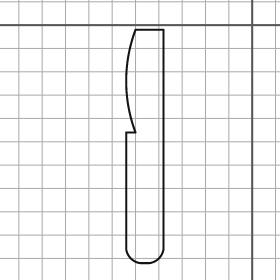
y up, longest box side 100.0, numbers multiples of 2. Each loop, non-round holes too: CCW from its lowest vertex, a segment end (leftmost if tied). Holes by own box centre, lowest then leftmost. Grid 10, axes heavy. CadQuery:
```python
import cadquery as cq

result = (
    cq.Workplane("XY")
    .moveTo(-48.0, -102.0)
    .lineTo(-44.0, -102.0)
    .threePointArc((-40.0, -100.0), (-38.0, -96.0))
    .lineTo(-38.0, -2.0)
    .lineTo(-50.0, -2.0)
    .threePointArc((-54.0, -24.0), (-50.0, -46.0))
    .lineTo(-54.0, -46.0)
    .lineTo(-54.0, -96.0)
    .threePointArc((-52.0, -100.0), (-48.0, -102.0))
    .close()
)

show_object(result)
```